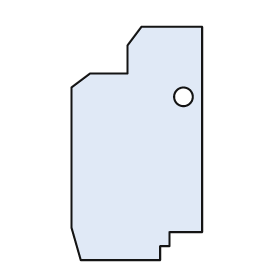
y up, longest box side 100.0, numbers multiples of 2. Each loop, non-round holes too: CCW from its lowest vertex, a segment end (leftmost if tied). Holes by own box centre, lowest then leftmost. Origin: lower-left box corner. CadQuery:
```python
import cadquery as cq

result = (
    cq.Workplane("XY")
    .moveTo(4.0, 0.0)
    .lineTo(38.0, 0.0)
    .lineTo(38.0, 6.0)
    .lineTo(42.0, 6.0)
    .lineTo(42.0, 12.0)
    .lineTo(56.0, 12.0)
    .lineTo(56.0, 100.0)
    .lineTo(30.0, 100.0)
    .lineTo(24.0, 92.0)
    .lineTo(24.0, 80.0)
    .lineTo(8.0, 80.0)
    .lineTo(0.0, 74.0)
    .lineTo(0.0, 14.0)
    .close()
    .moveTo(48.0, 70.0)
    .circle(4.0)
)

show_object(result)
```